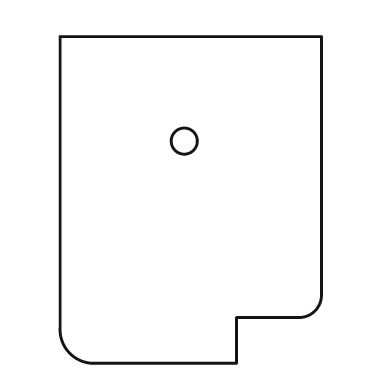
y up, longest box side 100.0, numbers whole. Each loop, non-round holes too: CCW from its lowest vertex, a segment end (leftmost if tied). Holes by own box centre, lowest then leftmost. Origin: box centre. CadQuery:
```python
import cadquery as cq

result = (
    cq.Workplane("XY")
    .moveTo(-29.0, -50.0)
    .lineTo(14.0, -50.0)
    .lineTo(14.0, -36.0)
    .lineTo(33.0, -36.0)
    .threePointArc((38.0, -34.0), (40.0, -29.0))
    .lineTo(40.0, 50.0)
    .lineTo(-40.0, 50.0)
    .lineTo(-40.0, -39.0)
    .threePointArc((-37.0, -47.0), (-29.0, -50.0))
    .close()
    .moveTo(-2.0, 18.0)
    .circle(4.0)
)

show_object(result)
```